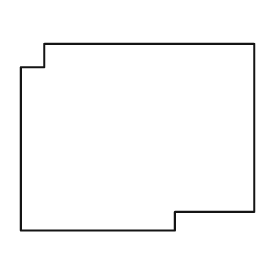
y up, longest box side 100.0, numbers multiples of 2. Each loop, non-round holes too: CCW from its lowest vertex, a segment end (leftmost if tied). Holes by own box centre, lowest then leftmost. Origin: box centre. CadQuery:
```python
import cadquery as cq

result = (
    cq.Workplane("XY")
    .moveTo(-50.0, -40.0)
    .lineTo(16.0, -40.0)
    .lineTo(16.0, -32.0)
    .lineTo(50.0, -32.0)
    .lineTo(50.0, 40.0)
    .lineTo(-40.0, 40.0)
    .lineTo(-40.0, 30.0)
    .lineTo(-50.0, 30.0)
    .close()
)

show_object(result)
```